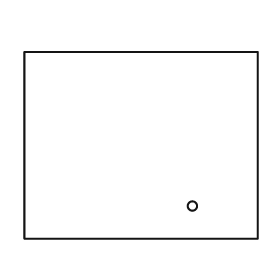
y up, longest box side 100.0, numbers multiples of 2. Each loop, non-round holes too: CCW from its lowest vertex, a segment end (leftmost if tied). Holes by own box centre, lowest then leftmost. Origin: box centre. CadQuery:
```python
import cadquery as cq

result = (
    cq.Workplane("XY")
    .moveTo(-50.0, -40.0)
    .lineTo(50.0, -40.0)
    .lineTo(50.0, 40.0)
    .lineTo(-50.0, 40.0)
    .close()
    .moveTo(22.0, -26.0)
    .circle(2.0)
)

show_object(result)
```